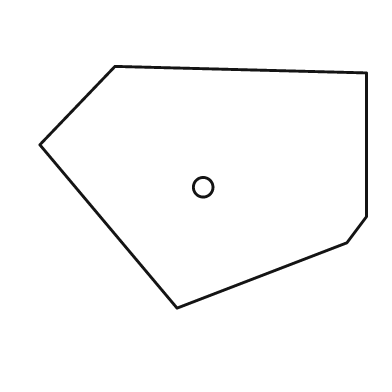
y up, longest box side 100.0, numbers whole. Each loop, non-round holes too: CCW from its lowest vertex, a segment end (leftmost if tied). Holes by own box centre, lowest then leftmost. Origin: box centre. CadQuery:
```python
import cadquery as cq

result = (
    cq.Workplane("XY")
    .moveTo(-8.0, -37.0)
    .lineTo(44.0, -17.0)
    .lineTo(50.0, -9.0)
    .lineTo(50.0, 35.0)
    .lineTo(-27.0, 37.0)
    .lineTo(-50.0, 13.0)
    .close()
    .moveTo(0.0, 0.0)
    .circle(3.0)
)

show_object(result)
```